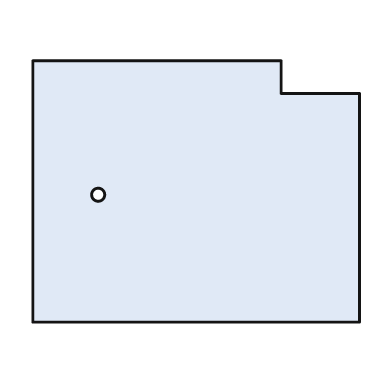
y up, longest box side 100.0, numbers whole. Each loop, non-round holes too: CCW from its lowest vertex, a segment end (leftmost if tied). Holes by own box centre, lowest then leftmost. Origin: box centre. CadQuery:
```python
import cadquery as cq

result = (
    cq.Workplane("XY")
    .moveTo(-50.0, -40.0)
    .lineTo(50.0, -40.0)
    .lineTo(50.0, 30.0)
    .lineTo(26.0, 30.0)
    .lineTo(26.0, 40.0)
    .lineTo(-50.0, 40.0)
    .close()
    .moveTo(-30.0, -1.0)
    .circle(2.0)
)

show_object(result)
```